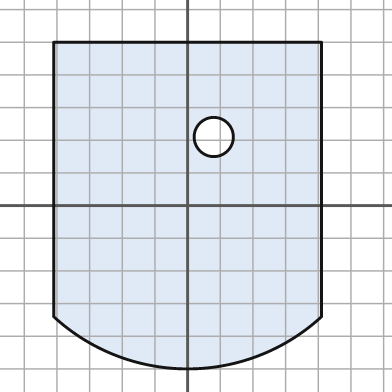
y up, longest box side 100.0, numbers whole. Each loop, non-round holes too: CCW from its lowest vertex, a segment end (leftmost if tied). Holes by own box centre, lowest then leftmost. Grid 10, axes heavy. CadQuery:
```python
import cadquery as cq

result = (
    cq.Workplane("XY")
    .moveTo(-41.0, -34.0)
    .threePointArc((0.0, -50.0), (41.0, -34.0))
    .lineTo(41.0, 50.0)
    .lineTo(-41.0, 50.0)
    .close()
    .moveTo(8.0, 21.0)
    .circle(6.0)
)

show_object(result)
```